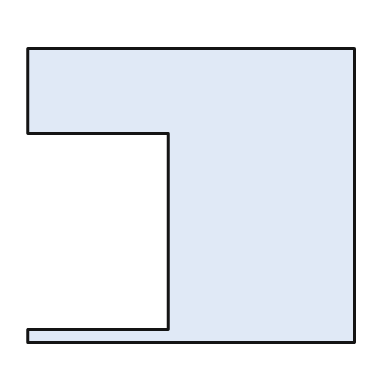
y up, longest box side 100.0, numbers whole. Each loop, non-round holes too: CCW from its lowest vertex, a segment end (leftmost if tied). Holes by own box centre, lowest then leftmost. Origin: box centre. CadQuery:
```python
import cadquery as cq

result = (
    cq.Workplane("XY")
    .moveTo(-50.0, -45.0)
    .lineTo(50.0, -45.0)
    .lineTo(50.0, 45.0)
    .lineTo(-50.0, 45.0)
    .lineTo(-50.0, 19.0)
    .lineTo(-7.0, 19.0)
    .lineTo(-7.0, -41.0)
    .lineTo(-50.0, -41.0)
    .close()
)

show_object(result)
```